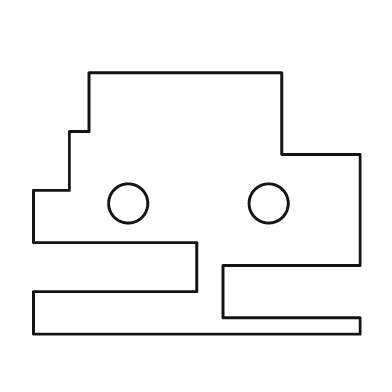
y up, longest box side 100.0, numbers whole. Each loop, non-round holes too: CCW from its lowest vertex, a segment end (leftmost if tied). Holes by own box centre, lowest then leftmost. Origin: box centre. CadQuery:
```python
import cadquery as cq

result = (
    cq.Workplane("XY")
    .moveTo(-50.0, -40.0)
    .lineTo(50.0, -40.0)
    .lineTo(50.0, -35.0)
    .lineTo(8.0, -35.0)
    .lineTo(8.0, -19.0)
    .lineTo(50.0, -19.0)
    .lineTo(50.0, 15.0)
    .lineTo(26.0, 15.0)
    .lineTo(26.0, 40.0)
    .lineTo(-33.0, 40.0)
    .lineTo(-33.0, 22.0)
    .lineTo(-39.0, 22.0)
    .lineTo(-39.0, 4.0)
    .lineTo(-50.0, 4.0)
    .lineTo(-50.0, -12.0)
    .lineTo(0.0, -12.0)
    .lineTo(0.0, -27.0)
    .lineTo(-50.0, -27.0)
    .close()
    .moveTo(-21.0, 0.0)
    .circle(6.0)
    .moveTo(22.0, 0.0)
    .circle(6.0)
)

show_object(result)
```